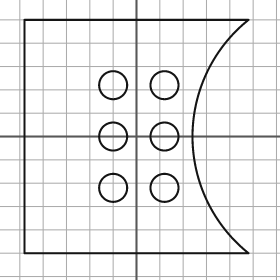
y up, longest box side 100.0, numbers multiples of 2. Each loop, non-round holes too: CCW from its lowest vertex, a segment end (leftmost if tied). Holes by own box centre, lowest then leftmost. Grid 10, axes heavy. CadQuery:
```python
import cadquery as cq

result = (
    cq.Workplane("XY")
    .moveTo(-48.0, -50.0)
    .lineTo(48.0, -50.0)
    .threePointArc((24.0, 0.0), (48.0, 50.0))
    .lineTo(-48.0, 50.0)
    .close()
    .moveTo(-10.0, -22.0)
    .circle(6.0)
    .moveTo(12.0, -22.0)
    .circle(6.0)
    .moveTo(-10.0, 0.0)
    .circle(6.0)
    .moveTo(12.0, 0.0)
    .circle(6.0)
    .moveTo(-10.0, 22.0)
    .circle(6.0)
    .moveTo(12.0, 22.0)
    .circle(6.0)
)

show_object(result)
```